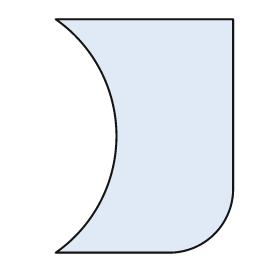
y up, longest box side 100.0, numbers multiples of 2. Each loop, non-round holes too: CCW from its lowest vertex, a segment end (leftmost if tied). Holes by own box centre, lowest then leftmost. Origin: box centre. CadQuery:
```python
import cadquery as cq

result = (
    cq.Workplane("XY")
    .moveTo(-38.0, -50.0)
    .lineTo(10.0, -50.0)
    .threePointArc((30.0, -42.0), (38.0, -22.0))
    .lineTo(38.0, 50.0)
    .lineTo(-38.0, 50.0)
    .threePointArc((-12.0, 0.0), (-38.0, -50.0))
    .close()
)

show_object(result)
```